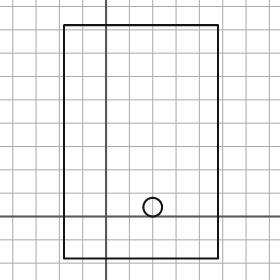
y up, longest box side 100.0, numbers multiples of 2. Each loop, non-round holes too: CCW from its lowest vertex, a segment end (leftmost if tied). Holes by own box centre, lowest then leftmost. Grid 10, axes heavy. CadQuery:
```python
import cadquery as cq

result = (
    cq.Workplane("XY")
    .moveTo(-18.0, -18.0)
    .lineTo(48.0, -18.0)
    .lineTo(48.0, 82.0)
    .lineTo(-18.0, 82.0)
    .close()
    .moveTo(20.0, 4.0)
    .circle(4.0)
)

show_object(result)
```